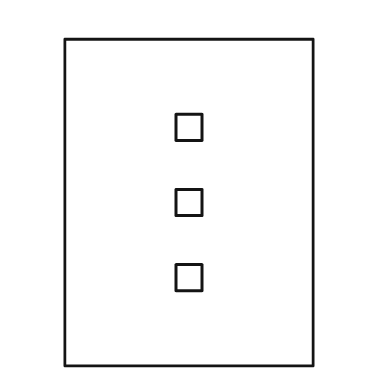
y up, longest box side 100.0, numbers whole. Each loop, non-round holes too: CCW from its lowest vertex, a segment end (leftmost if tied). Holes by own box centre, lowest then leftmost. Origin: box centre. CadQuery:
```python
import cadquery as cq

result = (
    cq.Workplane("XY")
    .moveTo(-38.0, -50.0)
    .lineTo(38.0, -50.0)
    .lineTo(38.0, 50.0)
    .lineTo(-38.0, 50.0)
    .close()
    .moveTo(-4.0, -27.0)
    .lineTo(4.0, -27.0)
    .lineTo(4.0, -19.0)
    .lineTo(-4.0, -19.0)
    .close()
    .moveTo(-4.0, -4.0)
    .lineTo(4.0, -4.0)
    .lineTo(4.0, 4.0)
    .lineTo(-4.0, 4.0)
    .close()
    .moveTo(-4.0, 19.0)
    .lineTo(4.0, 19.0)
    .lineTo(4.0, 27.0)
    .lineTo(-4.0, 27.0)
    .close()
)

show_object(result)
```